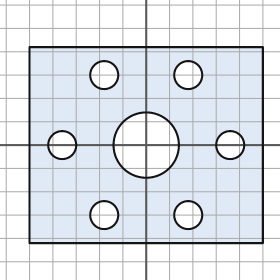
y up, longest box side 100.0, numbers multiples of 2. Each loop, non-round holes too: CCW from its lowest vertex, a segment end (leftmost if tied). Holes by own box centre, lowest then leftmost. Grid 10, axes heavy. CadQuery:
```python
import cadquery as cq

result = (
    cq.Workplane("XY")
    .moveTo(-50.0, -42.0)
    .lineTo(50.0, -42.0)
    .lineTo(50.0, 42.0)
    .lineTo(-50.0, 42.0)
    .close()
    .moveTo(-18.0, -30.0)
    .circle(6.0)
    .moveTo(18.0, -30.0)
    .circle(6.0)
    .moveTo(-36.0, 0.0)
    .circle(6.0)
    .moveTo(0.0, 0.0)
    .circle(14.0)
    .moveTo(36.0, 0.0)
    .circle(6.0)
    .moveTo(-18.0, 30.0)
    .circle(6.0)
    .moveTo(18.0, 30.0)
    .circle(6.0)
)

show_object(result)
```